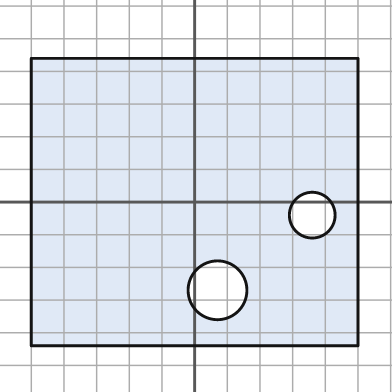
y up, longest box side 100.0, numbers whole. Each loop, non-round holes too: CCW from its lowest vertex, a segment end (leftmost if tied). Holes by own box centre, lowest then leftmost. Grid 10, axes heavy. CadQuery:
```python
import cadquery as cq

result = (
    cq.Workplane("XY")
    .moveTo(-50.0, -44.0)
    .lineTo(50.0, -44.0)
    .lineTo(50.0, 44.0)
    .lineTo(-50.0, 44.0)
    .close()
    .moveTo(7.0, -27.0)
    .circle(9.0)
    .moveTo(36.0, -4.0)
    .circle(7.0)
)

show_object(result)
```